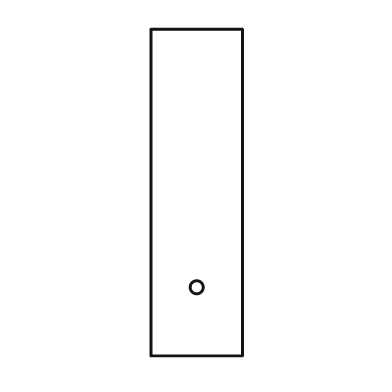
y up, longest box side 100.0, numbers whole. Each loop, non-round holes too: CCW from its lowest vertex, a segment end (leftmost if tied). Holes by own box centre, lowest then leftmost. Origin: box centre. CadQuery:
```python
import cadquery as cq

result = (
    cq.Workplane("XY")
    .moveTo(-14.0, -50.0)
    .lineTo(14.0, -50.0)
    .lineTo(14.0, 50.0)
    .lineTo(-14.0, 50.0)
    .close()
    .moveTo(0.0, -29.0)
    .circle(2.0)
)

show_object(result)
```